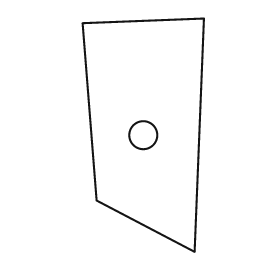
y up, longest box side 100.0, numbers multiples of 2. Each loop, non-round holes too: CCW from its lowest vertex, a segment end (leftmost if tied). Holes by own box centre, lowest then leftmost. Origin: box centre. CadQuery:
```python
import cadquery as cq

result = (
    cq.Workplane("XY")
    .moveTo(22.0, -50.0)
    .lineTo(26.0, 50.0)
    .lineTo(-26.0, 48.0)
    .lineTo(-20.0, -28.0)
    .close()
    .moveTo(0.0, 0.0)
    .circle(6.0)
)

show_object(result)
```